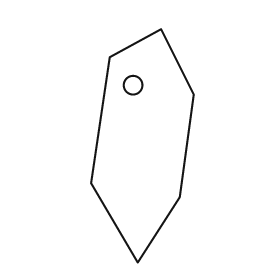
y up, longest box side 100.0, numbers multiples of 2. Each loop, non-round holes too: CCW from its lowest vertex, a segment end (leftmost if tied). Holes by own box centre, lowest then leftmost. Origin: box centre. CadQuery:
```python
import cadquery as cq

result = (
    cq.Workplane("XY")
    .moveTo(-2.0, -50.0)
    .lineTo(16.0, -22.0)
    .lineTo(22.0, 22.0)
    .lineTo(8.0, 50.0)
    .lineTo(-14.0, 38.0)
    .lineTo(-22.0, -16.0)
    .close()
    .moveTo(-4.0, 26.0)
    .circle(4.0)
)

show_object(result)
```